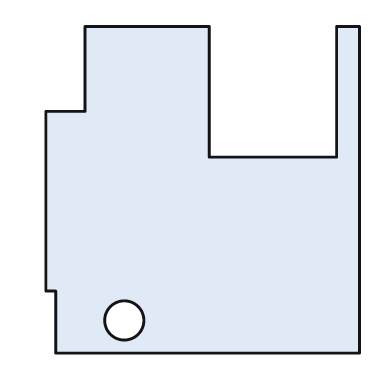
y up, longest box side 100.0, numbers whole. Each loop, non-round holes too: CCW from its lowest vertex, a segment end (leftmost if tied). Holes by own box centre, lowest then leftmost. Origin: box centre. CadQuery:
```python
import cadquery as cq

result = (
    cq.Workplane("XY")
    .moveTo(-45.0, -50.0)
    .lineTo(48.0, -50.0)
    .lineTo(48.0, 50.0)
    .lineTo(41.0, 50.0)
    .lineTo(41.0, 10.0)
    .lineTo(2.0, 10.0)
    .lineTo(2.0, 50.0)
    .lineTo(-36.0, 50.0)
    .lineTo(-36.0, 24.0)
    .lineTo(-48.0, 24.0)
    .lineTo(-48.0, -31.0)
    .lineTo(-45.0, -31.0)
    .close()
    .moveTo(-24.0, -40.0)
    .circle(6.0)
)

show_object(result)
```